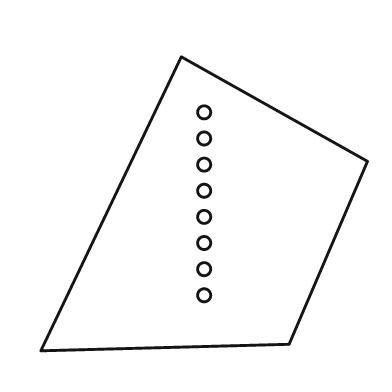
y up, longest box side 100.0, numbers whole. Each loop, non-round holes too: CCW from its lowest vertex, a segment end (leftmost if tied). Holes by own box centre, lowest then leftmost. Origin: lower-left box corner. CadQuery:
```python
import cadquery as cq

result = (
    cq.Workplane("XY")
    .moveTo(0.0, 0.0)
    .lineTo(76.0, 2.0)
    .lineTo(100.0, 58.0)
    .lineTo(43.0, 90.0)
    .close()
    .moveTo(50.0, 17.0)
    .circle(2.0)
    .moveTo(50.0, 25.0)
    .circle(2.0)
    .moveTo(50.0, 33.0)
    .circle(2.0)
    .moveTo(50.0, 41.0)
    .circle(2.0)
    .moveTo(50.0, 49.0)
    .circle(2.0)
    .moveTo(50.0, 57.0)
    .circle(2.0)
    .moveTo(50.0, 65.0)
    .circle(2.0)
    .moveTo(50.0, 73.0)
    .circle(2.0)
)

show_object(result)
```